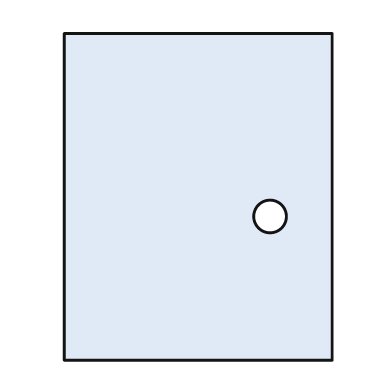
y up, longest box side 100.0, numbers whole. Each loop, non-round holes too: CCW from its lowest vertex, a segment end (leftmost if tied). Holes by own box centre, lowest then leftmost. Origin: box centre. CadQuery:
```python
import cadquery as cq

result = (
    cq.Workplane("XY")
    .moveTo(-41.0, -50.0)
    .lineTo(41.0, -50.0)
    .lineTo(41.0, 50.0)
    .lineTo(-41.0, 50.0)
    .close()
    .moveTo(22.0, -6.0)
    .circle(5.0)
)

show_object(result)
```